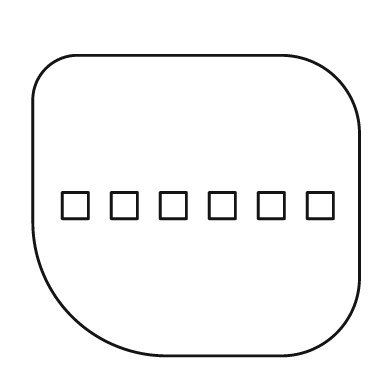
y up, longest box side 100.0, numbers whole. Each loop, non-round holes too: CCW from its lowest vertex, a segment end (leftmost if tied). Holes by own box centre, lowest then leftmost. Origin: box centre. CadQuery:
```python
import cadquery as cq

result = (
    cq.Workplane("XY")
    .moveTo(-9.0, -46.0)
    .lineTo(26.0, -46.0)
    .threePointArc((43.0, -39.0), (50.0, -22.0))
    .lineTo(50.0, 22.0)
    .threePointArc((43.0, 39.0), (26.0, 46.0))
    .lineTo(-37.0, 46.0)
    .threePointArc((-46.0, 42.0), (-50.0, 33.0))
    .lineTo(-50.0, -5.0)
    .threePointArc((-38.0, -34.0), (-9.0, -46.0))
    .close()
    .moveTo(-41.0, -4.0)
    .lineTo(-33.0, -4.0)
    .lineTo(-33.0, 4.0)
    .lineTo(-41.0, 4.0)
    .close()
    .moveTo(-26.0, -4.0)
    .lineTo(-18.0, -4.0)
    .lineTo(-18.0, 4.0)
    .lineTo(-26.0, 4.0)
    .close()
    .moveTo(-11.0, -4.0)
    .lineTo(-3.0, -4.0)
    .lineTo(-3.0, 4.0)
    .lineTo(-11.0, 4.0)
    .close()
    .moveTo(4.0, -4.0)
    .lineTo(12.0, -4.0)
    .lineTo(12.0, 4.0)
    .lineTo(4.0, 4.0)
    .close()
    .moveTo(19.0, -4.0)
    .lineTo(27.0, -4.0)
    .lineTo(27.0, 4.0)
    .lineTo(19.0, 4.0)
    .close()
    .moveTo(34.0, -4.0)
    .lineTo(42.0, -4.0)
    .lineTo(42.0, 4.0)
    .lineTo(34.0, 4.0)
    .close()
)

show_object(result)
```